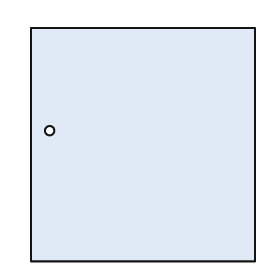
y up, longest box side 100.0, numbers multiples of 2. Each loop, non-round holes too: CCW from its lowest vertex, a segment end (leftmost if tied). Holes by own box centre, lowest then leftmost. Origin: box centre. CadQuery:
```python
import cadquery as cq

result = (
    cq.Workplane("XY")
    .moveTo(-48.0, -50.0)
    .lineTo(48.0, -50.0)
    .lineTo(48.0, 50.0)
    .lineTo(-48.0, 50.0)
    .close()
    .moveTo(-40.0, 6.0)
    .circle(2.0)
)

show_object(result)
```